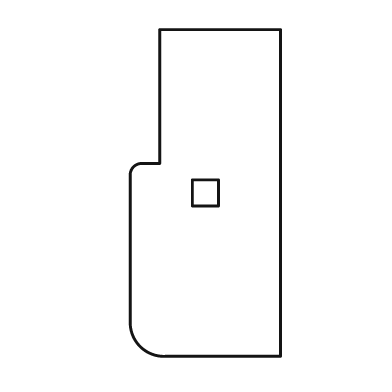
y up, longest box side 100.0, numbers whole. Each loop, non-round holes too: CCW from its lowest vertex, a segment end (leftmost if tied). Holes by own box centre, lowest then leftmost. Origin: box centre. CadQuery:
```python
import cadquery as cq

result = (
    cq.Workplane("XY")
    .moveTo(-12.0, -50.0)
    .lineTo(23.0, -50.0)
    .lineTo(23.0, 50.0)
    .lineTo(-14.0, 50.0)
    .lineTo(-14.0, 9.0)
    .lineTo(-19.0, 9.0)
    .threePointArc((-22.0, 8.0), (-23.0, 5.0))
    .lineTo(-23.0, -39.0)
    .threePointArc((-20.0, -47.0), (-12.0, -50.0))
    .close()
    .moveTo(-4.0, -4.0)
    .lineTo(4.0, -4.0)
    .lineTo(4.0, 4.0)
    .lineTo(-4.0, 4.0)
    .close()
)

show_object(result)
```